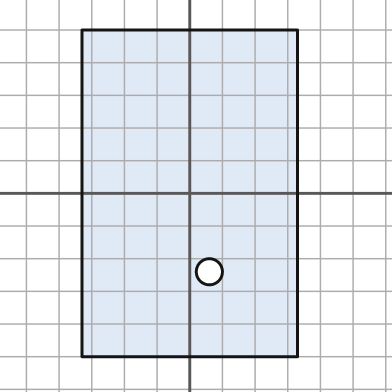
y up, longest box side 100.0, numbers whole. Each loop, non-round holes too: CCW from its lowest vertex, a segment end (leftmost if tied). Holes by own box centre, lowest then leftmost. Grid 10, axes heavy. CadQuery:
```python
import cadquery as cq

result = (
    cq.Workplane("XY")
    .moveTo(-33.0, -50.0)
    .lineTo(33.0, -50.0)
    .lineTo(33.0, 50.0)
    .lineTo(-33.0, 50.0)
    .close()
    .moveTo(6.0, -24.0)
    .circle(4.0)
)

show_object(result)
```